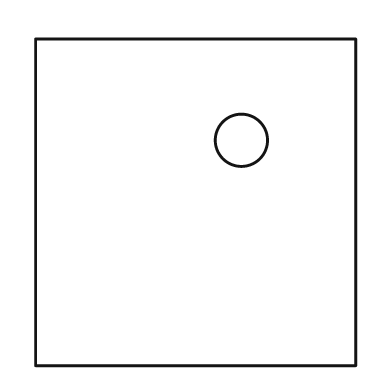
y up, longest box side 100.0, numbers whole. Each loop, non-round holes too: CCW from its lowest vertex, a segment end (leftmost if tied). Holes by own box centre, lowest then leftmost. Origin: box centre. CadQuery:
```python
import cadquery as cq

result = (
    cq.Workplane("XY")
    .moveTo(-49.0, -50.0)
    .lineTo(49.0, -50.0)
    .lineTo(49.0, 50.0)
    .lineTo(-49.0, 50.0)
    .close()
    .moveTo(14.0, 19.0)
    .circle(8.0)
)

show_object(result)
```